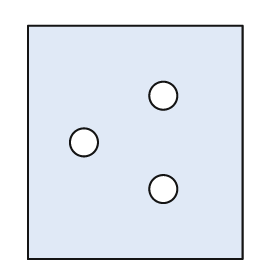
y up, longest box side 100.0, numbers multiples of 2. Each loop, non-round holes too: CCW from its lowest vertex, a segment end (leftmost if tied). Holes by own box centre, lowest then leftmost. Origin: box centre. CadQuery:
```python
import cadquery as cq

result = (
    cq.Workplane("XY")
    .moveTo(-46.0, -50.0)
    .lineTo(46.0, -50.0)
    .lineTo(46.0, 50.0)
    .lineTo(-46.0, 50.0)
    .close()
    .moveTo(12.0, -20.0)
    .circle(6.0)
    .moveTo(-22.0, 0.0)
    .circle(6.0)
    .moveTo(12.0, 20.0)
    .circle(6.0)
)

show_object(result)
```